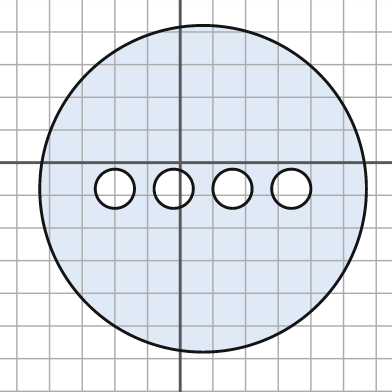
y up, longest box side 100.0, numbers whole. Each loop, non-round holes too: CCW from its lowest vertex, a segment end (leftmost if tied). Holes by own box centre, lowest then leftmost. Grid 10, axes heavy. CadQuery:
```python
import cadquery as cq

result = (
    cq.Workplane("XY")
    .moveTo(7.0, -8.0)
    .circle(50.0)
    .moveTo(-20.0, -8.0)
    .circle(6.0)
    .moveTo(-2.0, -8.0)
    .circle(6.0)
    .moveTo(16.0, -8.0)
    .circle(6.0)
    .moveTo(34.0, -8.0)
    .circle(6.0)
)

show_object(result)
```